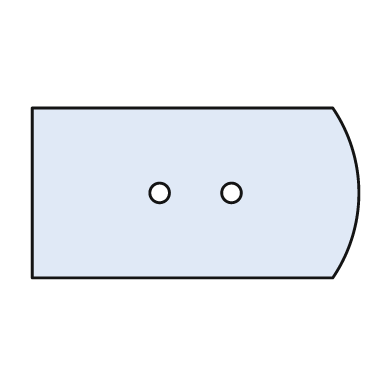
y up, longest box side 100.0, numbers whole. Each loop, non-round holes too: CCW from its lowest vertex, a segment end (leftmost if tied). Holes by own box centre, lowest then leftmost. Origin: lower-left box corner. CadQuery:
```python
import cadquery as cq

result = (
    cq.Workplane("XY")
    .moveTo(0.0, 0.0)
    .lineTo(92.0, 0.0)
    .threePointArc((100.0, 26.0), (92.0, 52.0))
    .lineTo(0.0, 52.0)
    .close()
    .moveTo(39.0, 26.0)
    .circle(3.0)
    .moveTo(61.0, 26.0)
    .circle(3.0)
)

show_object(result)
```